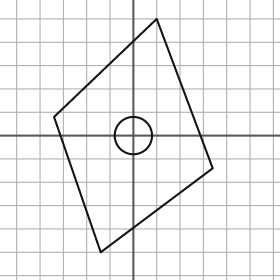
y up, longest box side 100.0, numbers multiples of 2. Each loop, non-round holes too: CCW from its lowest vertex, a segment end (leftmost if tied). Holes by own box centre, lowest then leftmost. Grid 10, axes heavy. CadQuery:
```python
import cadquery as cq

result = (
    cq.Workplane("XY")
    .moveTo(-14.0, -50.0)
    .lineTo(34.0, -14.0)
    .lineTo(10.0, 50.0)
    .lineTo(-34.0, 8.0)
    .close()
    .moveTo(0.0, 0.0)
    .circle(8.0)
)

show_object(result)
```